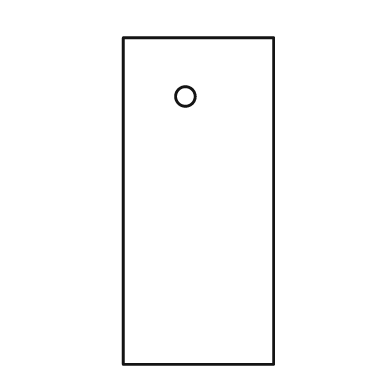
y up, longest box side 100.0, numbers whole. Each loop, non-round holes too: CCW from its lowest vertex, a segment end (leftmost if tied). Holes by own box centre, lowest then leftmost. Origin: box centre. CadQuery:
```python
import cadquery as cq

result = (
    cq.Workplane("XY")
    .moveTo(-23.0, -50.0)
    .lineTo(23.0, -50.0)
    .lineTo(23.0, 50.0)
    .lineTo(-23.0, 50.0)
    .close()
    .moveTo(-4.0, 32.0)
    .circle(3.0)
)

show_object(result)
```